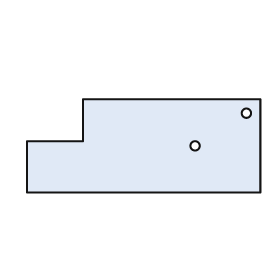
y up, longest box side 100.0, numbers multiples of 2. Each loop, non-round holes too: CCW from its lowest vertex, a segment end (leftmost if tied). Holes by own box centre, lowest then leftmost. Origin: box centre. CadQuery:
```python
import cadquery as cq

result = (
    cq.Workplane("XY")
    .moveTo(-50.0, -20.0)
    .lineTo(50.0, -20.0)
    .lineTo(50.0, 20.0)
    .lineTo(-26.0, 20.0)
    .lineTo(-26.0, 2.0)
    .lineTo(-50.0, 2.0)
    .close()
    .moveTo(22.0, 0.0)
    .circle(2.0)
    .moveTo(44.0, 14.0)
    .circle(2.0)
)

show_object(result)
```